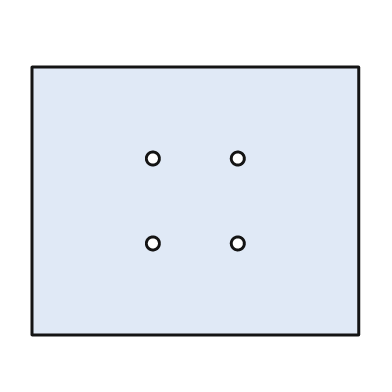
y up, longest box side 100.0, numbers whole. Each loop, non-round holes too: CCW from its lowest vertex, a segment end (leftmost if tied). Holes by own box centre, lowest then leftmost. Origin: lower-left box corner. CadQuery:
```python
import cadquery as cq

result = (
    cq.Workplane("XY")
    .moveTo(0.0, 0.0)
    .lineTo(100.0, 0.0)
    .lineTo(100.0, 82.0)
    .lineTo(0.0, 82.0)
    .close()
    .moveTo(37.0, 28.0)
    .circle(2.0)
    .moveTo(63.0, 28.0)
    .circle(2.0)
    .moveTo(37.0, 54.0)
    .circle(2.0)
    .moveTo(63.0, 54.0)
    .circle(2.0)
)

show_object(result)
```